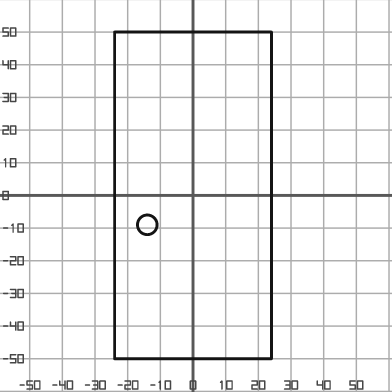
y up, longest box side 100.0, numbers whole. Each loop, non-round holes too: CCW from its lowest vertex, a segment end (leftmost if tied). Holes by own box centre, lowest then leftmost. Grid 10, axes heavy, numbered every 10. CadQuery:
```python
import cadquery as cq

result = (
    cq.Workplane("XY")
    .moveTo(-24.0, -50.0)
    .lineTo(24.0, -50.0)
    .lineTo(24.0, 50.0)
    .lineTo(-24.0, 50.0)
    .close()
    .moveTo(-14.0, -9.0)
    .circle(3.0)
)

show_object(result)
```